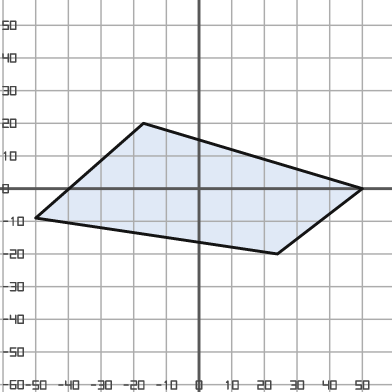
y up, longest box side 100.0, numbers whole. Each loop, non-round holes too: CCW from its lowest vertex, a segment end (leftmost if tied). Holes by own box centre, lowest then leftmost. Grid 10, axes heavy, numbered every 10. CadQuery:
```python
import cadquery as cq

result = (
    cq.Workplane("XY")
    .moveTo(24.0, -20.0)
    .lineTo(50.0, 0.0)
    .lineTo(-17.0, 20.0)
    .lineTo(-50.0, -9.0)
    .close()
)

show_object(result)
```